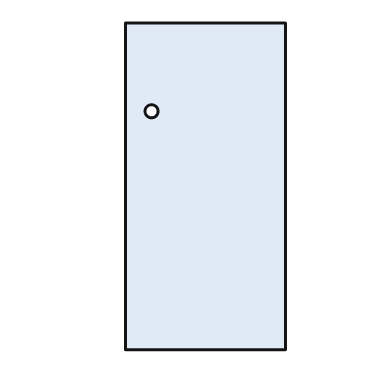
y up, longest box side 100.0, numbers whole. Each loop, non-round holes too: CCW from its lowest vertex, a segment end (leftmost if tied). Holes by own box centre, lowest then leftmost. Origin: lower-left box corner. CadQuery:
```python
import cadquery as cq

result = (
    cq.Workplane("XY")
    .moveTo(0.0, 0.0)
    .lineTo(49.0, 0.0)
    .lineTo(49.0, 100.0)
    .lineTo(0.0, 100.0)
    .close()
    .moveTo(8.0, 73.0)
    .circle(2.0)
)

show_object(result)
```